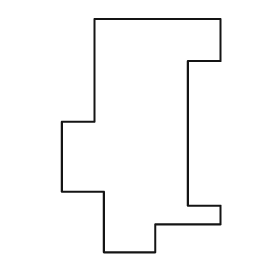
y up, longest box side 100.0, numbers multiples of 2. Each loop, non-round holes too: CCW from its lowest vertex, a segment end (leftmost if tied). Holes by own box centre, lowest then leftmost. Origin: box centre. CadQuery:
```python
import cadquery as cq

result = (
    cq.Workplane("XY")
    .moveTo(-16.0, -50.0)
    .lineTo(6.0, -50.0)
    .lineTo(6.0, -38.0)
    .lineTo(34.0, -38.0)
    .lineTo(34.0, -30.0)
    .lineTo(20.0, -30.0)
    .lineTo(20.0, 32.0)
    .lineTo(34.0, 32.0)
    .lineTo(34.0, 50.0)
    .lineTo(-20.0, 50.0)
    .lineTo(-20.0, 6.0)
    .lineTo(-34.0, 6.0)
    .lineTo(-34.0, -24.0)
    .lineTo(-16.0, -24.0)
    .close()
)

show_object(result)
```